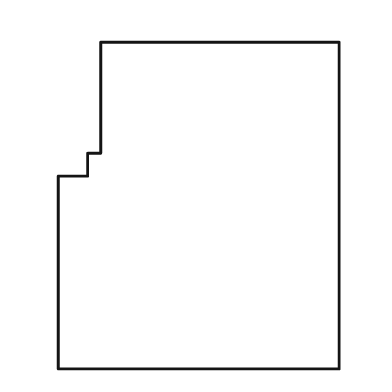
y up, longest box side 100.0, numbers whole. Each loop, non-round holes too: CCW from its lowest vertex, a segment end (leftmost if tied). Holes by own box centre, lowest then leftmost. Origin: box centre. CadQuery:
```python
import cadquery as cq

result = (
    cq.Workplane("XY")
    .moveTo(-43.0, -50.0)
    .lineTo(43.0, -50.0)
    .lineTo(43.0, 50.0)
    .lineTo(-30.0, 50.0)
    .lineTo(-30.0, 16.0)
    .lineTo(-34.0, 16.0)
    .lineTo(-34.0, 9.0)
    .lineTo(-43.0, 9.0)
    .close()
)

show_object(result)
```